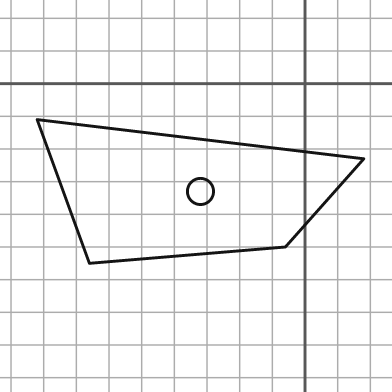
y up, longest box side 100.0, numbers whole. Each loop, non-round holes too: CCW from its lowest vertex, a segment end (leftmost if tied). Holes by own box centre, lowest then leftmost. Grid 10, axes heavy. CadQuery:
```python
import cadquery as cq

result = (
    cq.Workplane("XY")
    .moveTo(-66.0, -55.0)
    .lineTo(-6.0, -50.0)
    .lineTo(18.0, -23.0)
    .lineTo(-82.0, -11.0)
    .close()
    .moveTo(-32.0, -33.0)
    .circle(4.0)
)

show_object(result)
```